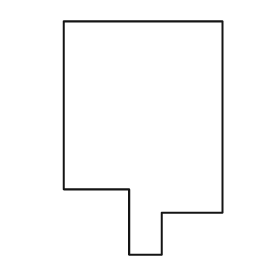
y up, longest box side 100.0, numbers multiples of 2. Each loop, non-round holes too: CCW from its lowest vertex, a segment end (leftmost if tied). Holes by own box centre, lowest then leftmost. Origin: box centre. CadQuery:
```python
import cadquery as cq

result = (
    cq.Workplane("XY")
    .moveTo(-6.0, -50.0)
    .lineTo(8.0, -50.0)
    .lineTo(8.0, -32.0)
    .lineTo(34.0, -32.0)
    .lineTo(34.0, 50.0)
    .lineTo(-34.0, 50.0)
    .lineTo(-34.0, -22.0)
    .lineTo(-6.0, -22.0)
    .close()
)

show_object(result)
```